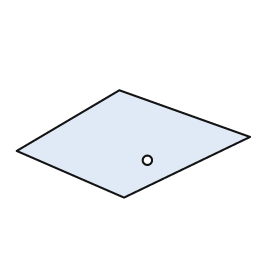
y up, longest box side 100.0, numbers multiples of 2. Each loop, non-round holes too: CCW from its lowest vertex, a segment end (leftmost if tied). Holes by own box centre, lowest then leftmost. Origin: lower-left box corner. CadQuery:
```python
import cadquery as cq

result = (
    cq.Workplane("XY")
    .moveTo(46.0, 0.0)
    .lineTo(100.0, 26.0)
    .lineTo(44.0, 46.0)
    .lineTo(0.0, 20.0)
    .close()
    .moveTo(56.0, 16.0)
    .circle(2.0)
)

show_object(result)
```